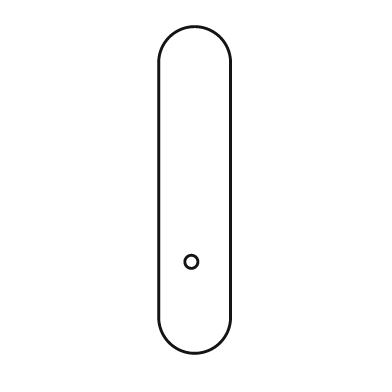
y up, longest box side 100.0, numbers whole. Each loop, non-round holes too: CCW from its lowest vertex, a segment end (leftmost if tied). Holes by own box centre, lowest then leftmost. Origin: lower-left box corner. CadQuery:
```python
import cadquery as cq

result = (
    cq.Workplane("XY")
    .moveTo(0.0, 11.0)
    .threePointArc((11.0, 0.0), (22.0, 11.0))
    .lineTo(22.0, 89.0)
    .threePointArc((11.0, 100.0), (0.0, 89.0))
    .close()
    .moveTo(10.0, 28.0)
    .circle(2.0)
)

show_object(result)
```